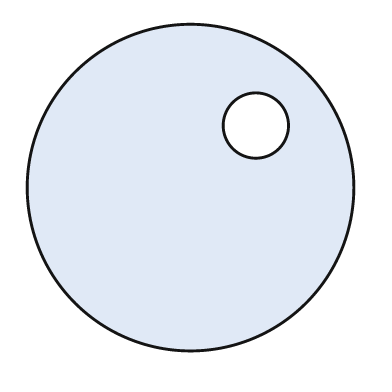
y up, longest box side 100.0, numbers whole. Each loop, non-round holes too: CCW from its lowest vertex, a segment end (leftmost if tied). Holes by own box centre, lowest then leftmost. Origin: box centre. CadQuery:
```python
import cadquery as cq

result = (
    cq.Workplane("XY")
    .moveTo(0.0, 0.0)
    .circle(50.0)
    .moveTo(20.0, 19.0)
    .circle(10.0)
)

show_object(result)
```